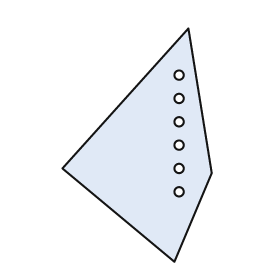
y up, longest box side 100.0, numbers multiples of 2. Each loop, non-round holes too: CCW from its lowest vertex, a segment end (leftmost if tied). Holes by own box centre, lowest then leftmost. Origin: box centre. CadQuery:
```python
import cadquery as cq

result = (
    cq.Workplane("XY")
    .moveTo(16.0, -50.0)
    .lineTo(32.0, -12.0)
    .lineTo(22.0, 50.0)
    .lineTo(-32.0, -10.0)
    .close()
    .moveTo(18.0, -20.0)
    .circle(2.0)
    .moveTo(18.0, -10.0)
    .circle(2.0)
    .moveTo(18.0, 0.0)
    .circle(2.0)
    .moveTo(18.0, 10.0)
    .circle(2.0)
    .moveTo(18.0, 20.0)
    .circle(2.0)
    .moveTo(18.0, 30.0)
    .circle(2.0)
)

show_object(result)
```